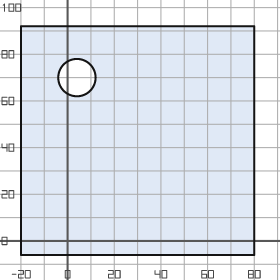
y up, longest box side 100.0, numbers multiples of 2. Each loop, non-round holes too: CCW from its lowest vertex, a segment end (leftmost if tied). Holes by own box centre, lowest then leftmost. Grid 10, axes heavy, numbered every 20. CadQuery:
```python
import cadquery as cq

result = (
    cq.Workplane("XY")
    .moveTo(-20.0, -6.0)
    .lineTo(80.0, -6.0)
    .lineTo(80.0, 92.0)
    .lineTo(-20.0, 92.0)
    .close()
    .moveTo(4.0, 70.0)
    .circle(8.0)
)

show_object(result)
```